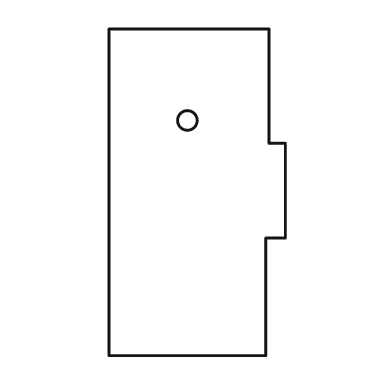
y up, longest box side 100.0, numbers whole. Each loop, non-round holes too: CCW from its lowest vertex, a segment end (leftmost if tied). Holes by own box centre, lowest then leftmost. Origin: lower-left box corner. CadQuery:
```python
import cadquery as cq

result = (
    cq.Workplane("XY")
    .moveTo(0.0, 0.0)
    .lineTo(48.0, 0.0)
    .lineTo(48.0, 36.0)
    .lineTo(54.0, 36.0)
    .lineTo(54.0, 65.0)
    .lineTo(49.0, 65.0)
    .lineTo(49.0, 100.0)
    .lineTo(0.0, 100.0)
    .close()
    .moveTo(24.0, 72.0)
    .circle(3.0)
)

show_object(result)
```